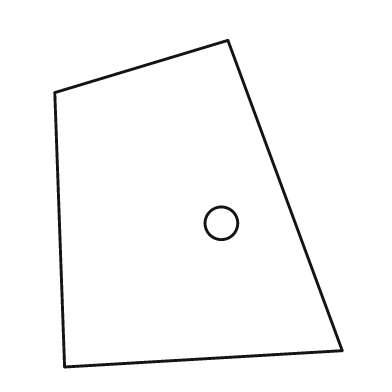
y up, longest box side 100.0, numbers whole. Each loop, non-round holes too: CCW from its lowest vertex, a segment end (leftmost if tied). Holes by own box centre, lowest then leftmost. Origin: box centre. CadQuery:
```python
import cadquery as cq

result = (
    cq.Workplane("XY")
    .moveTo(-41.0, -50.0)
    .lineTo(44.0, -45.0)
    .lineTo(9.0, 50.0)
    .lineTo(-44.0, 34.0)
    .close()
    .moveTo(7.0, -6.0)
    .circle(5.0)
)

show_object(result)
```